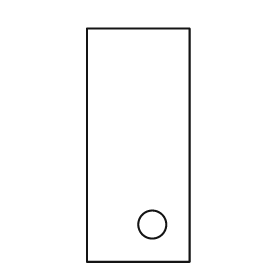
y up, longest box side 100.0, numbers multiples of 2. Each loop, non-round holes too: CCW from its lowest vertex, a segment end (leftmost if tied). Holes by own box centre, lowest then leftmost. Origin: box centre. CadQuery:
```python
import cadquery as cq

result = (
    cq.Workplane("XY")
    .moveTo(-22.0, -50.0)
    .lineTo(22.0, -50.0)
    .lineTo(22.0, 50.0)
    .lineTo(-22.0, 50.0)
    .close()
    .moveTo(6.0, -34.0)
    .circle(6.0)
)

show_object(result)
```